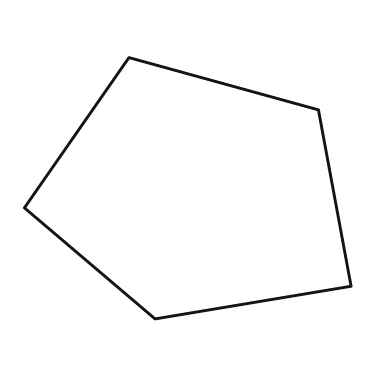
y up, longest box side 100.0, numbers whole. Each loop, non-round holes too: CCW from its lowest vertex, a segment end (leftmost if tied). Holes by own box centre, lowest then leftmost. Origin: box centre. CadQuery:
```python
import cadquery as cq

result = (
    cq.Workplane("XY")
    .moveTo(-10.0, -40.0)
    .lineTo(50.0, -30.0)
    .lineTo(40.0, 24.0)
    .lineTo(-18.0, 40.0)
    .lineTo(-50.0, -6.0)
    .close()
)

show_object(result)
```